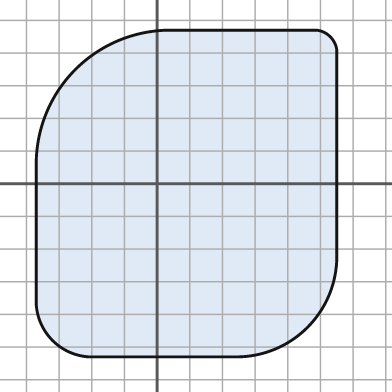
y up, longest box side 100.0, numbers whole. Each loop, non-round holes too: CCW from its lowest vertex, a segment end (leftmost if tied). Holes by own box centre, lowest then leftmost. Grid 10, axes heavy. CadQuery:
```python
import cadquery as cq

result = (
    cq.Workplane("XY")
    .moveTo(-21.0, -53.0)
    .lineTo(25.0, -53.0)
    .threePointArc((46.0, -44.0), (55.0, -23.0))
    .lineTo(55.0, 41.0)
    .threePointArc((53.0, 45.0), (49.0, 47.0))
    .lineTo(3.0, 47.0)
    .threePointArc((-25.0, 35.0), (-37.0, 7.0))
    .lineTo(-37.0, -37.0)
    .threePointArc((-32.0, -48.0), (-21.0, -53.0))
    .close()
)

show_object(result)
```